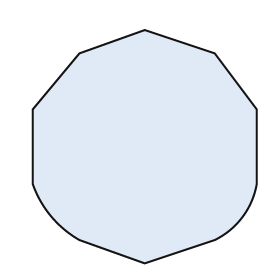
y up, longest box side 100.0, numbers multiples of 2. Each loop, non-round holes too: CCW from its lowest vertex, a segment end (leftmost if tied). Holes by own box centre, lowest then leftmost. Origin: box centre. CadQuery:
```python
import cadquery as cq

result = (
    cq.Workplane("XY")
    .moveTo(0.0, -50.0)
    .lineTo(30.0, -40.0)
    .threePointArc((42.0, -30.0), (48.0, -16.0))
    .lineTo(48.0, 16.0)
    .lineTo(30.0, 40.0)
    .lineTo(0.0, 50.0)
    .lineTo(-28.0, 40.0)
    .lineTo(-48.0, 16.0)
    .lineTo(-48.0, -16.0)
    .threePointArc((-40.0, -30.0), (-28.0, -40.0))
    .close()
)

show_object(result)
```